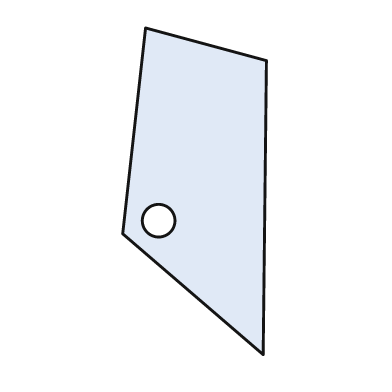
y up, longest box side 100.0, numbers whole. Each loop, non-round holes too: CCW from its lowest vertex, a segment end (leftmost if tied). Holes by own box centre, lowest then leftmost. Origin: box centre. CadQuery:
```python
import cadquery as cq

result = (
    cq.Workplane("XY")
    .moveTo(21.0, -50.0)
    .lineTo(22.0, 40.0)
    .lineTo(-15.0, 50.0)
    .lineTo(-22.0, -13.0)
    .close()
    .moveTo(-11.0, -9.0)
    .circle(5.0)
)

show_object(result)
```